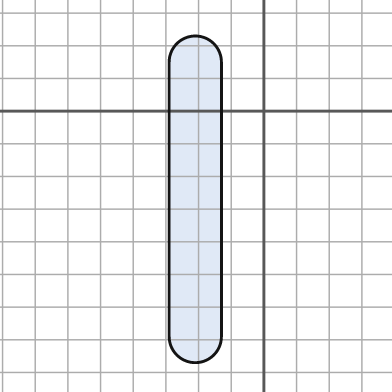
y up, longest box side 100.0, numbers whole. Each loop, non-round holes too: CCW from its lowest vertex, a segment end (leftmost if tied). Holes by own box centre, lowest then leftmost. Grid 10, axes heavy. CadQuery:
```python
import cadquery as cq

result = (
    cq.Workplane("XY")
    .moveTo(-29.0, -69.0)
    .threePointArc((-21.0, -77.0), (-13.0, -69.0))
    .lineTo(-13.0, 15.0)
    .threePointArc((-21.0, 23.0), (-29.0, 15.0))
    .close()
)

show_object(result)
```